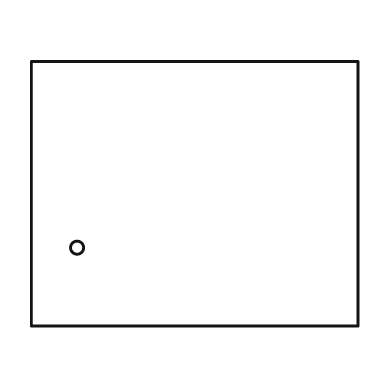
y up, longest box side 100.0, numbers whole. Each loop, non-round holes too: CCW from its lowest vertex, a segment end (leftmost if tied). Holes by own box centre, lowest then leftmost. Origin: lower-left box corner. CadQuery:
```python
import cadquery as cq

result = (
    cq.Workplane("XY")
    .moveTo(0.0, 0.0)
    .lineTo(100.0, 0.0)
    .lineTo(100.0, 81.0)
    .lineTo(0.0, 81.0)
    .close()
    .moveTo(14.0, 24.0)
    .circle(2.0)
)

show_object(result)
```